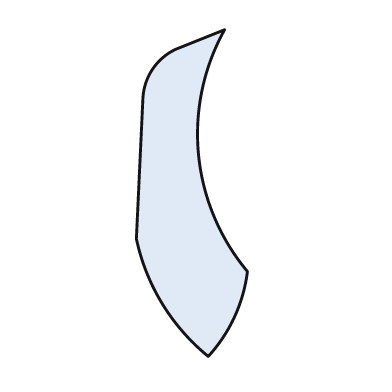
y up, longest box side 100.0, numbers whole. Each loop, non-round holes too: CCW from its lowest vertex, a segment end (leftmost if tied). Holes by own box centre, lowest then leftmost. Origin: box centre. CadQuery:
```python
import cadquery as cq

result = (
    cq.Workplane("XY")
    .moveTo(5.0, -50.0)
    .threePointArc((13.0, -38.0), (17.0, -24.0))
    .threePointArc((2.0, 12.0), (10.0, 50.0))
    .lineTo(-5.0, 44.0)
    .threePointArc((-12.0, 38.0), (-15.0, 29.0))
    .lineTo(-17.0, -14.0)
    .threePointArc((-9.0, -34.0), (5.0, -50.0))
    .close()
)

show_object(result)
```